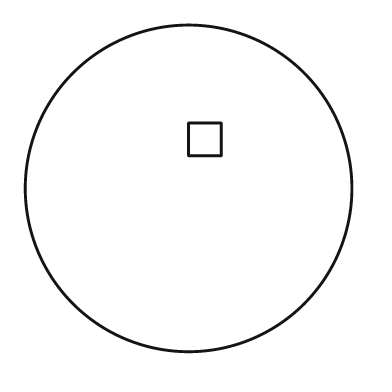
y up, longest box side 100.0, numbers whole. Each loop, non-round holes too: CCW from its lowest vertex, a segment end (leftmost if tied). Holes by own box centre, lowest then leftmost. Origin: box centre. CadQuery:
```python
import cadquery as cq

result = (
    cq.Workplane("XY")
    .moveTo(0.0, 0.0)
    .circle(50.0)
    .moveTo(0.0, 10.0)
    .lineTo(10.0, 10.0)
    .lineTo(10.0, 20.0)
    .lineTo(0.0, 20.0)
    .close()
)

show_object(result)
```